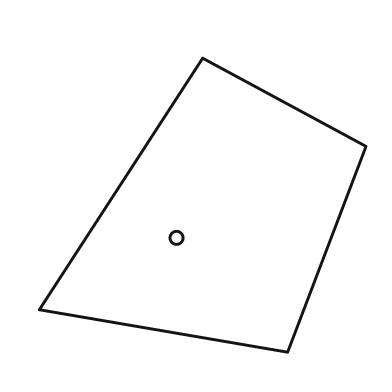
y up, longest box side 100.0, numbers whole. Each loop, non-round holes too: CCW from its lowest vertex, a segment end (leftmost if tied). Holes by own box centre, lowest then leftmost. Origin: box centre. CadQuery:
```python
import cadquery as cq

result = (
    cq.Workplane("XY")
    .moveTo(26.0, -45.0)
    .lineTo(50.0, 18.0)
    .lineTo(0.0, 45.0)
    .lineTo(-50.0, -32.0)
    .close()
    .moveTo(-8.0, -10.0)
    .circle(2.0)
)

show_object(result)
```